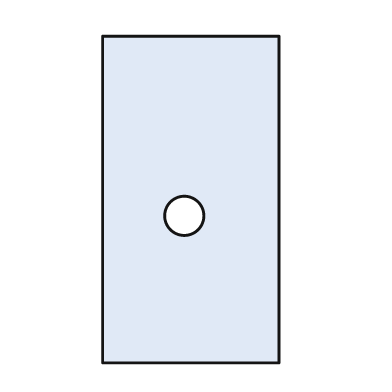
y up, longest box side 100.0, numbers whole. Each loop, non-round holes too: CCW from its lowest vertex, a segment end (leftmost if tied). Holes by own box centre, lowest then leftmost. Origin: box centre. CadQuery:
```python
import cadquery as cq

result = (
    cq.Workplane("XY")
    .moveTo(-27.0, -50.0)
    .lineTo(27.0, -50.0)
    .lineTo(27.0, 50.0)
    .lineTo(-27.0, 50.0)
    .close()
    .moveTo(-2.0, -5.0)
    .circle(6.0)
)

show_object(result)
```